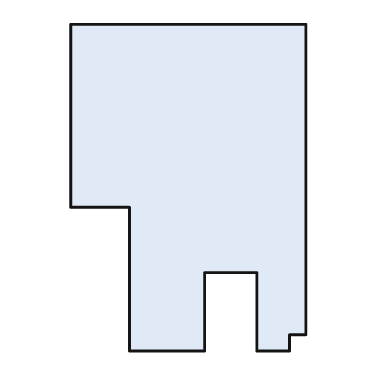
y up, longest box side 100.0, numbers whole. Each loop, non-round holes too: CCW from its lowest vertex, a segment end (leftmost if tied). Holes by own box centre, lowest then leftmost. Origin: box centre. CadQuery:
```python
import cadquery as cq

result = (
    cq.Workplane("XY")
    .moveTo(-18.0, -50.0)
    .lineTo(5.0, -50.0)
    .lineTo(5.0, -26.0)
    .lineTo(21.0, -26.0)
    .lineTo(21.0, -50.0)
    .lineTo(31.0, -50.0)
    .lineTo(31.0, -45.0)
    .lineTo(36.0, -45.0)
    .lineTo(36.0, 50.0)
    .lineTo(-36.0, 50.0)
    .lineTo(-36.0, -6.0)
    .lineTo(-18.0, -6.0)
    .close()
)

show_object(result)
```